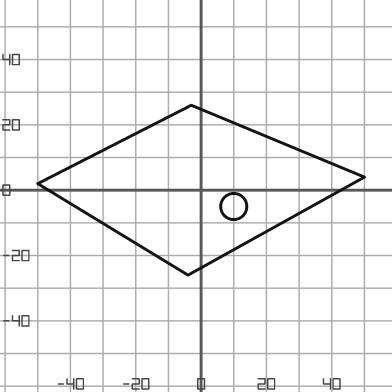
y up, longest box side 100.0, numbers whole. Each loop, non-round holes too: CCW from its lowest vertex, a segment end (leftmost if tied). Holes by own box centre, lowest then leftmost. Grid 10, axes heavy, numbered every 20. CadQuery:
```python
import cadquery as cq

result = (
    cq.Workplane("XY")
    .moveTo(-4.0, -26.0)
    .lineTo(50.0, 4.0)
    .lineTo(-3.0, 26.0)
    .lineTo(-50.0, 2.0)
    .close()
    .moveTo(10.0, -5.0)
    .circle(4.0)
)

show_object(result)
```